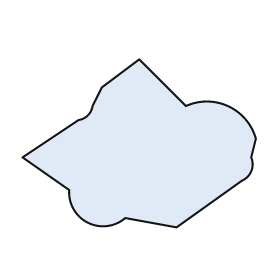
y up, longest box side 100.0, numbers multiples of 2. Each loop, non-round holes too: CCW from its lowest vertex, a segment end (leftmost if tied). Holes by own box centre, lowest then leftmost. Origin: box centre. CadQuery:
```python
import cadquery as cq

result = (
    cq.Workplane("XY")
    .moveTo(16.0, -36.0)
    .lineTo(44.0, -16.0)
    .threePointArc((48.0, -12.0), (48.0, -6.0))
    .lineTo(50.0, 2.0)
    .threePointArc((38.0, 16.0), (20.0, 16.0))
    .lineTo(0.0, 36.0)
    .lineTo(-16.0, 24.0)
    .lineTo(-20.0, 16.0)
    .threePointArc((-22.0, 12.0), (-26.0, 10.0))
    .lineTo(-50.0, -6.0)
    .lineTo(-30.0, -20.0)
    .threePointArc((-22.0, -34.0), (-6.0, -32.0))
    .close()
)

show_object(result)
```